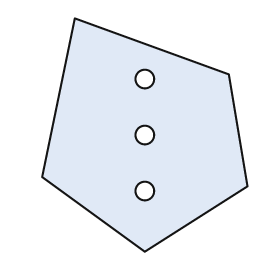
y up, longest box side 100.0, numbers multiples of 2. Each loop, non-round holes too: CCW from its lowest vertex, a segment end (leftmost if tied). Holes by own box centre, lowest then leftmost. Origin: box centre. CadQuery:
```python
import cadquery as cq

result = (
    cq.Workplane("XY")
    .moveTo(0.0, -50.0)
    .lineTo(44.0, -22.0)
    .lineTo(36.0, 26.0)
    .lineTo(-30.0, 50.0)
    .lineTo(-44.0, -18.0)
    .close()
    .moveTo(0.0, -24.0)
    .circle(4.0)
    .moveTo(0.0, 0.0)
    .circle(4.0)
    .moveTo(0.0, 24.0)
    .circle(4.0)
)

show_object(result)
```